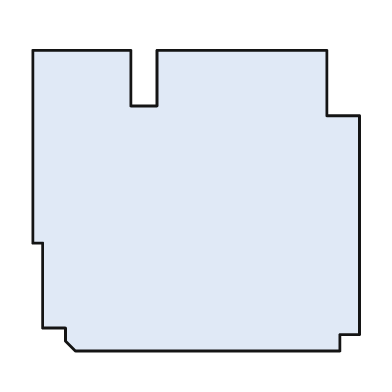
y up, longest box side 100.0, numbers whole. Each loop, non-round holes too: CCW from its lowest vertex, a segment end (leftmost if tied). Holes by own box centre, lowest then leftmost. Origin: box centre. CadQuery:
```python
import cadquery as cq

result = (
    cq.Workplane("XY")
    .moveTo(-37.0, -46.0)
    .lineTo(44.0, -46.0)
    .lineTo(44.0, -41.0)
    .lineTo(50.0, -41.0)
    .lineTo(50.0, 26.0)
    .lineTo(40.0, 26.0)
    .lineTo(40.0, 46.0)
    .lineTo(-12.0, 46.0)
    .lineTo(-12.0, 29.0)
    .lineTo(-20.0, 29.0)
    .lineTo(-20.0, 46.0)
    .lineTo(-50.0, 46.0)
    .lineTo(-50.0, -13.0)
    .lineTo(-47.0, -13.0)
    .lineTo(-47.0, -39.0)
    .lineTo(-40.0, -39.0)
    .lineTo(-40.0, -43.0)
    .close()
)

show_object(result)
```